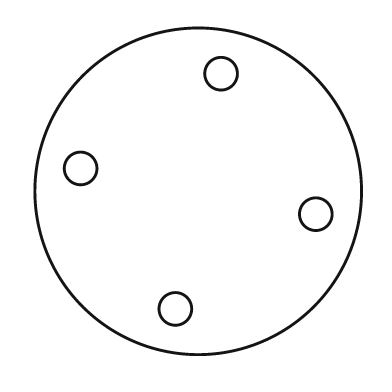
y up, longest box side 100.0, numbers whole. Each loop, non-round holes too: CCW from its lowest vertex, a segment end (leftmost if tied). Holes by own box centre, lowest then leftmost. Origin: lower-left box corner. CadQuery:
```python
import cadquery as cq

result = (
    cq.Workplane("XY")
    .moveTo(50.0, 50.0)
    .circle(50.0)
    .moveTo(43.0, 14.0)
    .circle(5.0)
    .moveTo(86.0, 43.0)
    .circle(5.0)
    .moveTo(14.0, 57.0)
    .circle(5.0)
    .moveTo(57.0, 86.0)
    .circle(5.0)
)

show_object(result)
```